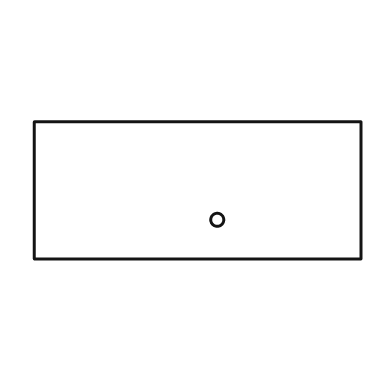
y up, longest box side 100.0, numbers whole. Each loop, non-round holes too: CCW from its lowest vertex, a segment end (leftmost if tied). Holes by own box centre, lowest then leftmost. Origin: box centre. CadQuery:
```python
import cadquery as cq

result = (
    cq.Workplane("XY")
    .moveTo(-50.0, -21.0)
    .lineTo(50.0, -21.0)
    .lineTo(50.0, 21.0)
    .lineTo(-50.0, 21.0)
    .close()
    .moveTo(6.0, -9.0)
    .circle(2.0)
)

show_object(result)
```